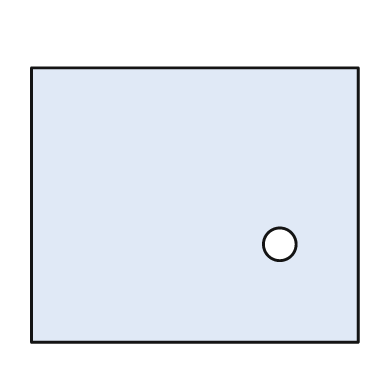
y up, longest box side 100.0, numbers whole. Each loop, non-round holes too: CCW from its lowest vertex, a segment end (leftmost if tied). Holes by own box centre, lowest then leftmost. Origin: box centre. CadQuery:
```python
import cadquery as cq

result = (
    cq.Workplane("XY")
    .moveTo(-50.0, -42.0)
    .lineTo(50.0, -42.0)
    .lineTo(50.0, 42.0)
    .lineTo(-50.0, 42.0)
    .close()
    .moveTo(26.0, -12.0)
    .circle(5.0)
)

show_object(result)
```